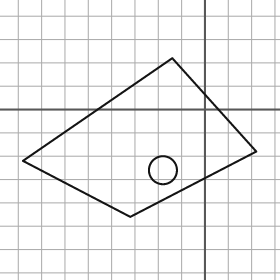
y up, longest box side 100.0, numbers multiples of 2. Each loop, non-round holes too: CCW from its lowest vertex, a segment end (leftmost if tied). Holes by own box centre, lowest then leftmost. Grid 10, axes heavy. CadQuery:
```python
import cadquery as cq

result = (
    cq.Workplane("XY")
    .moveTo(-32.0, -46.0)
    .lineTo(22.0, -18.0)
    .lineTo(-14.0, 22.0)
    .lineTo(-78.0, -22.0)
    .close()
    .moveTo(-18.0, -26.0)
    .circle(6.0)
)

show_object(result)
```